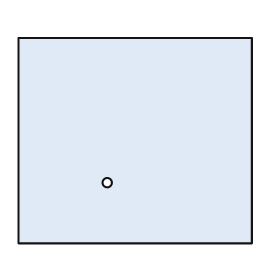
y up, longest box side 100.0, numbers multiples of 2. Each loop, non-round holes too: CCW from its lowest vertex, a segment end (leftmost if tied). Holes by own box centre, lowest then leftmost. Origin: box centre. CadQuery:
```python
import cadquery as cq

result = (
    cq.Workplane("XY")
    .moveTo(-50.0, -44.0)
    .lineTo(50.0, -44.0)
    .lineTo(50.0, 44.0)
    .lineTo(-50.0, 44.0)
    .close()
    .moveTo(-12.0, -18.0)
    .circle(2.0)
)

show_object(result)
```